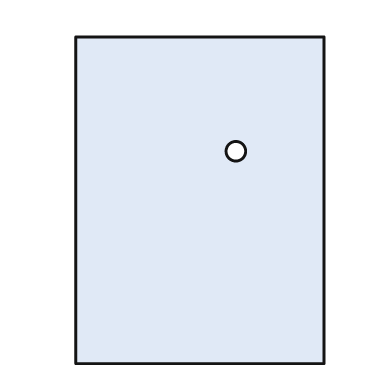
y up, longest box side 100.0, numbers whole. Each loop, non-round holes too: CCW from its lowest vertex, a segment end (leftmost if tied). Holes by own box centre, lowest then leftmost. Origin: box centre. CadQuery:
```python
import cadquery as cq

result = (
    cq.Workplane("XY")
    .moveTo(-38.0, -50.0)
    .lineTo(38.0, -50.0)
    .lineTo(38.0, 50.0)
    .lineTo(-38.0, 50.0)
    .close()
    .moveTo(11.0, 15.0)
    .circle(3.0)
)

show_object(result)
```